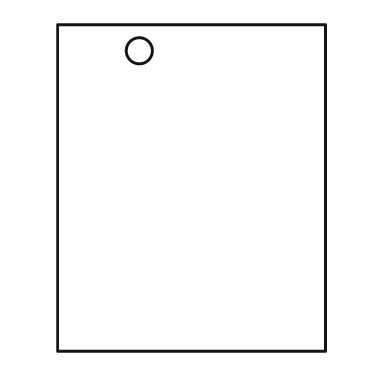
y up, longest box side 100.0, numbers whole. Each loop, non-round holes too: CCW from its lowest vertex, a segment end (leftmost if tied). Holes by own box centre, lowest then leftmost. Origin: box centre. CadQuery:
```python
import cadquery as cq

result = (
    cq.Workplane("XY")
    .moveTo(-41.0, -50.0)
    .lineTo(41.0, -50.0)
    .lineTo(41.0, 50.0)
    .lineTo(-41.0, 50.0)
    .close()
    .moveTo(-16.0, 42.0)
    .circle(4.0)
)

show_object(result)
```